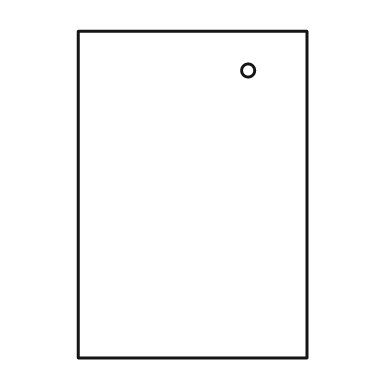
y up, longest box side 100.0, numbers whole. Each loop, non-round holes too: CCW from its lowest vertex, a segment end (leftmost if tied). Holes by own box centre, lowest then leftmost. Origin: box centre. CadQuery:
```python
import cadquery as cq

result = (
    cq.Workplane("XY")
    .moveTo(-35.0, -50.0)
    .lineTo(35.0, -50.0)
    .lineTo(35.0, 50.0)
    .lineTo(-35.0, 50.0)
    .close()
    .moveTo(17.0, 38.0)
    .circle(2.0)
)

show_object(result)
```